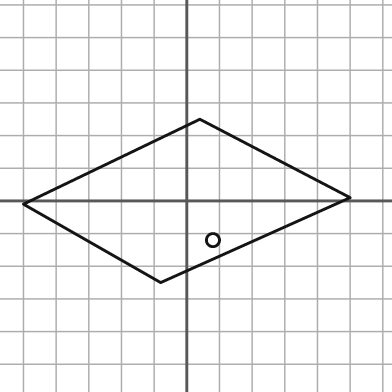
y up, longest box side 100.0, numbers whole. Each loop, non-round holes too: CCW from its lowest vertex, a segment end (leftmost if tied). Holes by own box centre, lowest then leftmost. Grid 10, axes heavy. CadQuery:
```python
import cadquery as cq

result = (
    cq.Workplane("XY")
    .moveTo(-8.0, -25.0)
    .lineTo(50.0, 1.0)
    .lineTo(4.0, 25.0)
    .lineTo(-50.0, -1.0)
    .close()
    .moveTo(8.0, -12.0)
    .circle(2.0)
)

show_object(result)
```